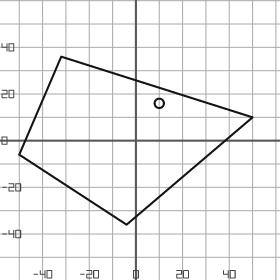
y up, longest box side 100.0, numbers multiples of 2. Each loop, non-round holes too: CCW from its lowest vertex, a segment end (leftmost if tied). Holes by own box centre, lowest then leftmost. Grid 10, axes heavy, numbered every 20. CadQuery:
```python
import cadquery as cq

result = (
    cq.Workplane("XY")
    .moveTo(-4.0, -36.0)
    .lineTo(50.0, 10.0)
    .lineTo(-32.0, 36.0)
    .lineTo(-50.0, -6.0)
    .close()
    .moveTo(10.0, 16.0)
    .circle(2.0)
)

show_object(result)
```